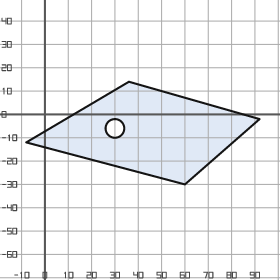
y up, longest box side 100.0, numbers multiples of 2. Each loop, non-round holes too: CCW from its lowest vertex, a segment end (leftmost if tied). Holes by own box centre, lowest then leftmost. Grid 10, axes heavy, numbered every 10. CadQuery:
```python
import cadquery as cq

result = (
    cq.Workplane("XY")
    .moveTo(60.0, -30.0)
    .lineTo(92.0, -2.0)
    .lineTo(36.0, 14.0)
    .lineTo(-8.0, -12.0)
    .close()
    .moveTo(30.0, -6.0)
    .circle(4.0)
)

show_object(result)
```